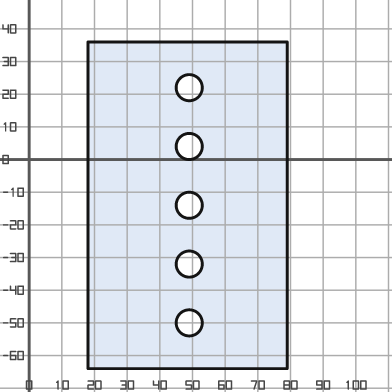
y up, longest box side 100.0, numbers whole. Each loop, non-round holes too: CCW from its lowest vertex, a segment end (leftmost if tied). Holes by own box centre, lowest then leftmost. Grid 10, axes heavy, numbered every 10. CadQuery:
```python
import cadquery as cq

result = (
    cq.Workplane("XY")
    .moveTo(18.0, -64.0)
    .lineTo(79.0, -64.0)
    .lineTo(79.0, 36.0)
    .lineTo(18.0, 36.0)
    .close()
    .moveTo(49.0, -50.0)
    .circle(4.0)
    .moveTo(49.0, -32.0)
    .circle(4.0)
    .moveTo(49.0, -14.0)
    .circle(4.0)
    .moveTo(49.0, 4.0)
    .circle(4.0)
    .moveTo(49.0, 22.0)
    .circle(4.0)
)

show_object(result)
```